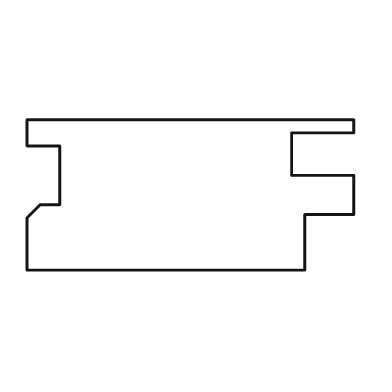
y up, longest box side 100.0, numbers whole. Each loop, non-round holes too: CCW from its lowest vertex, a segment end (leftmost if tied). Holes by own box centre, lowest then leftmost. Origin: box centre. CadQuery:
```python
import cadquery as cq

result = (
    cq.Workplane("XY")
    .moveTo(-50.0, -23.0)
    .lineTo(35.0, -23.0)
    .lineTo(35.0, -6.0)
    .lineTo(50.0, -6.0)
    .lineTo(50.0, 6.0)
    .lineTo(31.0, 6.0)
    .lineTo(31.0, 19.0)
    .lineTo(50.0, 19.0)
    .lineTo(50.0, 23.0)
    .lineTo(-50.0, 23.0)
    .lineTo(-50.0, 15.0)
    .lineTo(-40.0, 15.0)
    .lineTo(-40.0, -3.0)
    .lineTo(-46.0, -3.0)
    .lineTo(-50.0, -7.0)
    .close()
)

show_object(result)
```